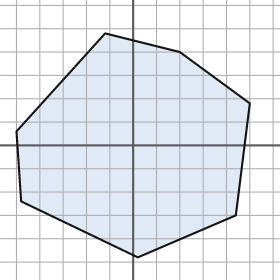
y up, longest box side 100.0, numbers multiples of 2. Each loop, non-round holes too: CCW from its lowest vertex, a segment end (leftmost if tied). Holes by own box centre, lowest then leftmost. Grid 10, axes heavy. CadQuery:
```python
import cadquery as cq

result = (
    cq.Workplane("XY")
    .moveTo(2.0, -48.0)
    .lineTo(44.0, -30.0)
    .lineTo(50.0, 18.0)
    .lineTo(20.0, 40.0)
    .lineTo(-12.0, 48.0)
    .lineTo(-50.0, 6.0)
    .lineTo(-48.0, -24.0)
    .close()
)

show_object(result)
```